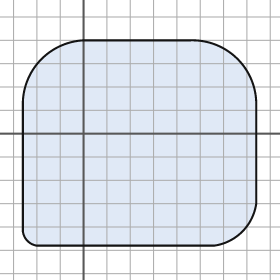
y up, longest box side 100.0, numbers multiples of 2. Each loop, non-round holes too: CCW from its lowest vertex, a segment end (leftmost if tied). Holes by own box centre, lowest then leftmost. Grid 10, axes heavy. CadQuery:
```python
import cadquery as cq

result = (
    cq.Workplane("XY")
    .moveTo(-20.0, -48.0)
    .lineTo(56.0, -48.0)
    .threePointArc((68.0, -42.0), (74.0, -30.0))
    .lineTo(74.0, 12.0)
    .threePointArc((66.0, 32.0), (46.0, 40.0))
    .lineTo(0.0, 40.0)
    .threePointArc((-18.0, 32.0), (-26.0, 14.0))
    .lineTo(-26.0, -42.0)
    .threePointArc((-24.0, -46.0), (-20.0, -48.0))
    .close()
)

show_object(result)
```